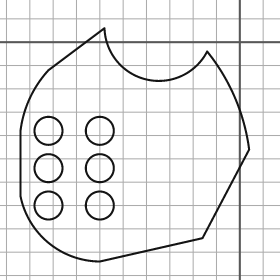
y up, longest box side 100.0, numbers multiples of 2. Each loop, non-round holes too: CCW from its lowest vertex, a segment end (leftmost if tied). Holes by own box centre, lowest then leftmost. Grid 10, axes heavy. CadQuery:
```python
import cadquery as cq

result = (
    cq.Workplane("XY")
    .moveTo(-60.0, -94.0)
    .lineTo(-16.0, -84.0)
    .lineTo(4.0, -46.0)
    .threePointArc((-2.0, -24.0), (-14.0, -4.0))
    .threePointArc((-40.0, -16.0), (-58.0, 6.0))
    .lineTo(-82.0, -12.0)
    .threePointArc((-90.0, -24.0), (-94.0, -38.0))
    .lineTo(-94.0, -66.0)
    .threePointArc((-82.0, -86.0), (-60.0, -94.0))
    .close()
    .moveTo(-82.0, -70.0)
    .circle(6.0)
    .moveTo(-60.0, -70.0)
    .circle(6.0)
    .moveTo(-82.0, -54.0)
    .circle(6.0)
    .moveTo(-60.0, -54.0)
    .circle(6.0)
    .moveTo(-82.0, -38.0)
    .circle(6.0)
    .moveTo(-60.0, -38.0)
    .circle(6.0)
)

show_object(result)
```